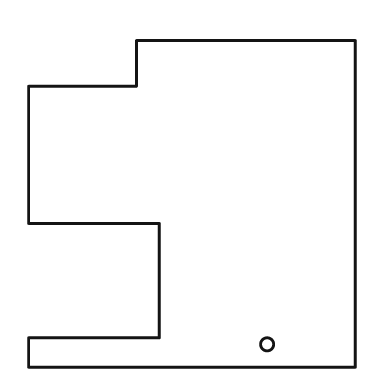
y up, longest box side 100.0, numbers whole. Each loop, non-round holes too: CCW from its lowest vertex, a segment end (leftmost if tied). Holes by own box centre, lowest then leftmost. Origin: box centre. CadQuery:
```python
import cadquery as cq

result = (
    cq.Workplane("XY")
    .moveTo(-50.0, -50.0)
    .lineTo(50.0, -50.0)
    .lineTo(50.0, 50.0)
    .lineTo(-17.0, 50.0)
    .lineTo(-17.0, 36.0)
    .lineTo(-50.0, 36.0)
    .lineTo(-50.0, -6.0)
    .lineTo(-10.0, -6.0)
    .lineTo(-10.0, -41.0)
    .lineTo(-50.0, -41.0)
    .close()
    .moveTo(23.0, -43.0)
    .circle(2.0)
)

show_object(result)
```